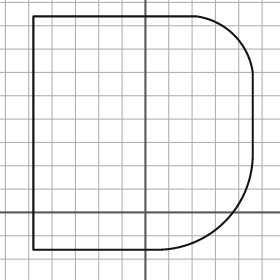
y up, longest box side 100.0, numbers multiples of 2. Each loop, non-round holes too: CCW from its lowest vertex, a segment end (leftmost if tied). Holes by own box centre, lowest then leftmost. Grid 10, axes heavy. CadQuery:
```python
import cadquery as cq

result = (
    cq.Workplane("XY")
    .moveTo(-48.0, -16.0)
    .lineTo(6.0, -16.0)
    .threePointArc((34.0, -4.0), (46.0, 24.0))
    .lineTo(46.0, 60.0)
    .threePointArc((38.0, 76.0), (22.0, 84.0))
    .lineTo(-48.0, 84.0)
    .close()
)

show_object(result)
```